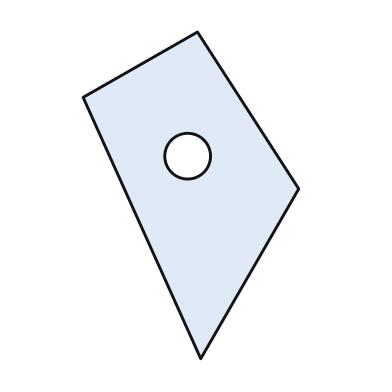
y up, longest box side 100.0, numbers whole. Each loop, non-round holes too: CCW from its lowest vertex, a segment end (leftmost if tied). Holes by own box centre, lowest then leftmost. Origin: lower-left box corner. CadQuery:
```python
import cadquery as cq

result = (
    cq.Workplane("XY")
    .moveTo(36.0, 0.0)
    .lineTo(66.0, 52.0)
    .lineTo(35.0, 100.0)
    .lineTo(0.0, 80.0)
    .close()
    .moveTo(32.0, 62.0)
    .circle(7.0)
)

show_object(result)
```